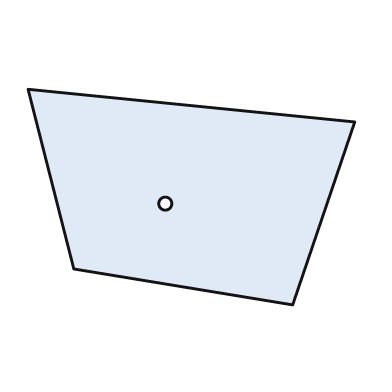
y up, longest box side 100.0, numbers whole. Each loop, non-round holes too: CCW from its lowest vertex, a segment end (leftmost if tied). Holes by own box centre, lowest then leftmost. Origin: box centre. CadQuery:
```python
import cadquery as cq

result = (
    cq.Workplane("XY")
    .moveTo(31.0, -33.0)
    .lineTo(50.0, 23.0)
    .lineTo(-50.0, 33.0)
    .lineTo(-36.0, -22.0)
    .close()
    .moveTo(-8.0, -2.0)
    .circle(2.0)
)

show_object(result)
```